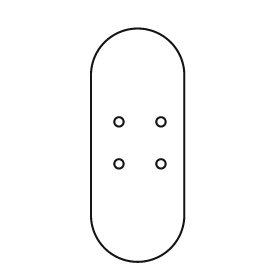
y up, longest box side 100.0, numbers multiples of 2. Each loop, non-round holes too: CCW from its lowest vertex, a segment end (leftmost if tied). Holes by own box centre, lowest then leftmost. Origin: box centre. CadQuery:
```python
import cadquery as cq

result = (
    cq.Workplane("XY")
    .moveTo(-20.0, -30.0)
    .threePointArc((0.0, -50.0), (20.0, -30.0))
    .lineTo(20.0, 30.0)
    .threePointArc((0.0, 50.0), (-20.0, 30.0))
    .close()
    .moveTo(-8.0, -8.0)
    .circle(2.0)
    .moveTo(10.0, -8.0)
    .circle(2.0)
    .moveTo(-8.0, 10.0)
    .circle(2.0)
    .moveTo(10.0, 10.0)
    .circle(2.0)
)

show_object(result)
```